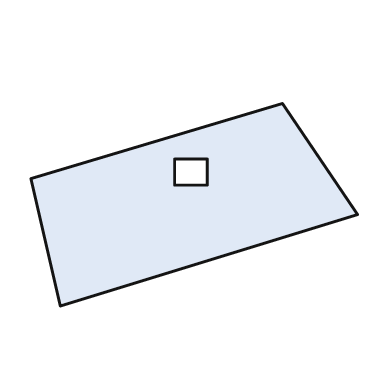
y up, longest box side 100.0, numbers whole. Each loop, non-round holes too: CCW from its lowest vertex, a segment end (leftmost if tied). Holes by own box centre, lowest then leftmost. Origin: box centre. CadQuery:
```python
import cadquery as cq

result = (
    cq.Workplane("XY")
    .moveTo(-41.0, -31.0)
    .lineTo(50.0, -3.0)
    .lineTo(27.0, 31.0)
    .lineTo(-50.0, 8.0)
    .close()
    .moveTo(-6.0, 6.0)
    .lineTo(4.0, 6.0)
    .lineTo(4.0, 14.0)
    .lineTo(-6.0, 14.0)
    .close()
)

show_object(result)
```